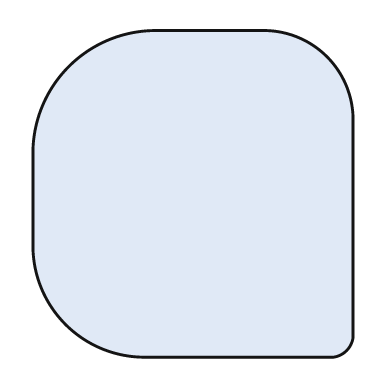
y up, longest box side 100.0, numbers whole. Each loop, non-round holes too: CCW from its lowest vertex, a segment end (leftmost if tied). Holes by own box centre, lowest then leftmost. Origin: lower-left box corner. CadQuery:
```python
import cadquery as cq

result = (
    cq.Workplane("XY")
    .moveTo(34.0, 0.0)
    .lineTo(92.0, 0.0)
    .threePointArc((96.0, 2.0), (98.0, 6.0))
    .lineTo(98.0, 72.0)
    .threePointArc((90.0, 92.0), (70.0, 100.0))
    .lineTo(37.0, 100.0)
    .threePointArc((11.0, 89.0), (0.0, 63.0))
    .lineTo(0.0, 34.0)
    .threePointArc((10.0, 10.0), (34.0, 0.0))
    .close()
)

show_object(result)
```